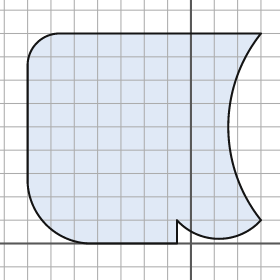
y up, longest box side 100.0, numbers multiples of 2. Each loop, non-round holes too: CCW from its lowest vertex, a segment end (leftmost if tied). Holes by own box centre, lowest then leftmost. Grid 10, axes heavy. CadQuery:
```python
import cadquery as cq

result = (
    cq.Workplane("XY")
    .moveTo(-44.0, 0.0)
    .lineTo(-6.0, 0.0)
    .lineTo(-6.0, 10.0)
    .threePointArc((12.0, 2.0), (30.0, 10.0))
    .threePointArc((16.0, 50.0), (30.0, 90.0))
    .lineTo(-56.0, 90.0)
    .threePointArc((-66.0, 86.0), (-70.0, 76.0))
    .lineTo(-70.0, 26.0)
    .threePointArc((-62.0, 8.0), (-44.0, 0.0))
    .close()
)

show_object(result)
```